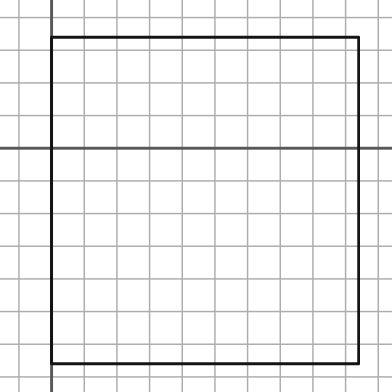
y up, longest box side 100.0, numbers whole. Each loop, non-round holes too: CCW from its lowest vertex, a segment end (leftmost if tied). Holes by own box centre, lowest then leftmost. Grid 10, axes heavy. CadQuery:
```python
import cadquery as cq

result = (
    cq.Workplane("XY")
    .moveTo(0.0, -66.0)
    .lineTo(94.0, -66.0)
    .lineTo(94.0, 34.0)
    .lineTo(0.0, 34.0)
    .close()
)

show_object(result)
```